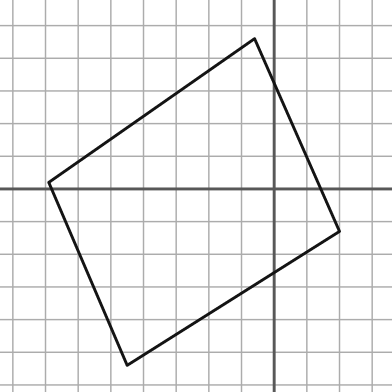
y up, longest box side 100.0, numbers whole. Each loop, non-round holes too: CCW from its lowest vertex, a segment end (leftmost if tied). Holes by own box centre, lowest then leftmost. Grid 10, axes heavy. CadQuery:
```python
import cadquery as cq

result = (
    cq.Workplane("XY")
    .moveTo(-45.0, -54.0)
    .lineTo(20.0, -13.0)
    .lineTo(-6.0, 46.0)
    .lineTo(-69.0, 2.0)
    .close()
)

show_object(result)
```